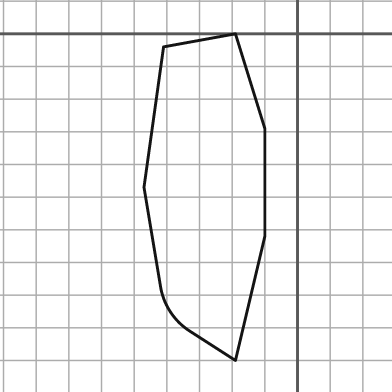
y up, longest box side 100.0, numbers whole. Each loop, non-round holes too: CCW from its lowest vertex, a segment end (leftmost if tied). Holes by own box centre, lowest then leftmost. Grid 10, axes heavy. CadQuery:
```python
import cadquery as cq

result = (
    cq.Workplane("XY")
    .moveTo(-19.0, -100.0)
    .lineTo(-10.0, -62.0)
    .lineTo(-10.0, -29.0)
    .lineTo(-19.0, 0.0)
    .lineTo(-41.0, -4.0)
    .lineTo(-47.0, -47.0)
    .lineTo(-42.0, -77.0)
    .threePointArc((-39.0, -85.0), (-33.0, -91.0))
    .close()
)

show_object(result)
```